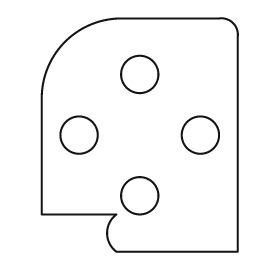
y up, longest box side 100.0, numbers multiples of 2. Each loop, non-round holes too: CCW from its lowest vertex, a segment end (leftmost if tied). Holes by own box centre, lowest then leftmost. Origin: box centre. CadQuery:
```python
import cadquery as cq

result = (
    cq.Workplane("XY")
    .moveTo(-10.0, -50.0)
    .lineTo(42.0, -50.0)
    .lineTo(42.0, 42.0)
    .threePointArc((40.0, 48.0), (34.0, 50.0))
    .lineTo(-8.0, 50.0)
    .threePointArc((-32.0, 40.0), (-42.0, 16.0))
    .lineTo(-42.0, -34.0)
    .lineTo(-10.0, -34.0)
    .threePointArc((-14.0, -42.0), (-10.0, -50.0))
    .close()
    .moveTo(0.0, -26.0)
    .circle(8.0)
    .moveTo(-26.0, 0.0)
    .circle(8.0)
    .moveTo(26.0, 0.0)
    .circle(8.0)
    .moveTo(0.0, 26.0)
    .circle(8.0)
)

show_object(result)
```